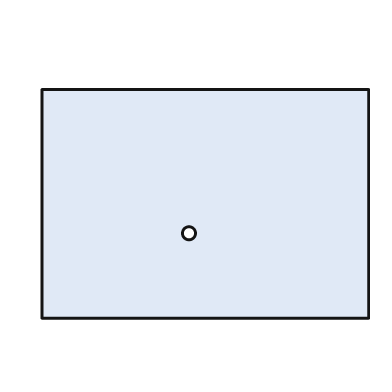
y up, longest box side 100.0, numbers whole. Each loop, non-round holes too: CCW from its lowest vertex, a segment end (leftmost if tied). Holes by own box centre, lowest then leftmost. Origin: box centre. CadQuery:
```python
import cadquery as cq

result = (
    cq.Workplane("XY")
    .moveTo(-50.0, -35.0)
    .lineTo(50.0, -35.0)
    .lineTo(50.0, 35.0)
    .lineTo(-50.0, 35.0)
    .close()
    .moveTo(-5.0, -9.0)
    .circle(2.0)
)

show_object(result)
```